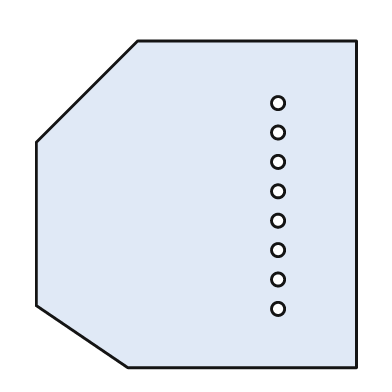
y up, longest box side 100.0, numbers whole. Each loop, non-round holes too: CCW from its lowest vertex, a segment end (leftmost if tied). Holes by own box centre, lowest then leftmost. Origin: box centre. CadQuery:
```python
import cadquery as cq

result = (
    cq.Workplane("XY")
    .moveTo(-21.0, -50.0)
    .lineTo(49.0, -50.0)
    .lineTo(49.0, 50.0)
    .lineTo(-18.0, 50.0)
    .lineTo(-49.0, 19.0)
    .lineTo(-49.0, -31.0)
    .close()
    .moveTo(25.0, -32.0)
    .circle(2.0)
    .moveTo(25.0, -23.0)
    .circle(2.0)
    .moveTo(25.0, -14.0)
    .circle(2.0)
    .moveTo(25.0, -5.0)
    .circle(2.0)
    .moveTo(25.0, 4.0)
    .circle(2.0)
    .moveTo(25.0, 13.0)
    .circle(2.0)
    .moveTo(25.0, 22.0)
    .circle(2.0)
    .moveTo(25.0, 31.0)
    .circle(2.0)
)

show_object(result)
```